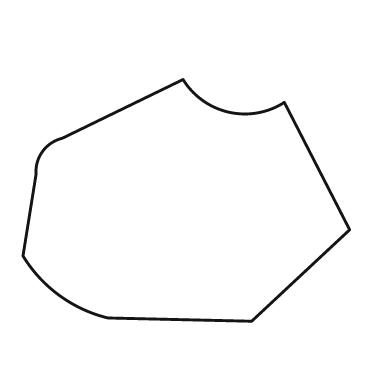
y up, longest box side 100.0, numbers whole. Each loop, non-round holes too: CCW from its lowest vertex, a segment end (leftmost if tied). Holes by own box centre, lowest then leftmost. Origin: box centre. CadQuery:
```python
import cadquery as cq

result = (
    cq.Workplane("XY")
    .moveTo(20.0, -37.0)
    .lineTo(50.0, -9.0)
    .lineTo(30.0, 30.0)
    .threePointArc((13.0, 27.0), (-1.0, 37.0))
    .lineTo(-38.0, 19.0)
    .threePointArc((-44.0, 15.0), (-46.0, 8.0))
    .lineTo(-50.0, -17.0)
    .threePointArc((-39.0, -29.0), (-24.0, -36.0))
    .close()
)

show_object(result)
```